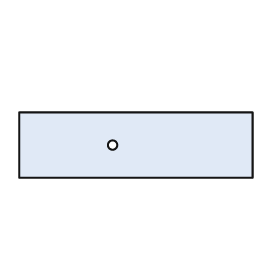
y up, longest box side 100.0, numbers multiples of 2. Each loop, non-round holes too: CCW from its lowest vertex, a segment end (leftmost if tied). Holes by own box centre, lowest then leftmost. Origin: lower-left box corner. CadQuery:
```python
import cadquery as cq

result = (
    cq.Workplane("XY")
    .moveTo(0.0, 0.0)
    .lineTo(100.0, 0.0)
    .lineTo(100.0, 28.0)
    .lineTo(0.0, 28.0)
    .close()
    .moveTo(40.0, 14.0)
    .circle(2.0)
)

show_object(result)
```